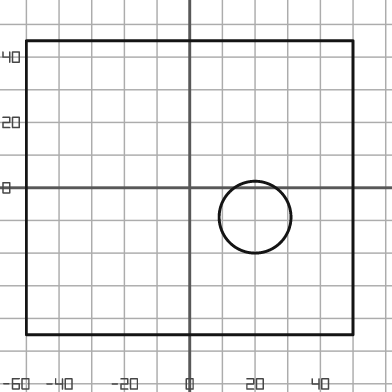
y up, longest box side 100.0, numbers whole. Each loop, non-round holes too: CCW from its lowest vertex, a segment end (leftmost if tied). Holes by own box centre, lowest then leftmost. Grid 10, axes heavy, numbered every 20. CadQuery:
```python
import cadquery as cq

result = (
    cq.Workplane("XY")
    .moveTo(-50.0, -45.0)
    .lineTo(50.0, -45.0)
    .lineTo(50.0, 45.0)
    .lineTo(-50.0, 45.0)
    .close()
    .moveTo(20.0, -9.0)
    .circle(11.0)
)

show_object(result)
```